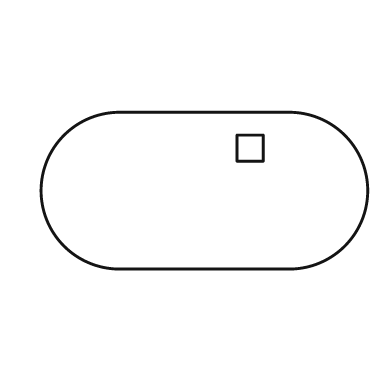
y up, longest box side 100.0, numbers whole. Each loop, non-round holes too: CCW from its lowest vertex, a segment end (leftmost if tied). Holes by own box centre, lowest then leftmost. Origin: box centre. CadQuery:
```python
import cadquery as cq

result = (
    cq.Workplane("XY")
    .moveTo(-26.0, -24.0)
    .lineTo(26.0, -24.0)
    .threePointArc((50.0, 0.0), (26.0, 24.0))
    .lineTo(-26.0, 24.0)
    .threePointArc((-50.0, 0.0), (-26.0, -24.0))
    .close()
    .moveTo(10.0, 9.0)
    .lineTo(18.0, 9.0)
    .lineTo(18.0, 17.0)
    .lineTo(10.0, 17.0)
    .close()
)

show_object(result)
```